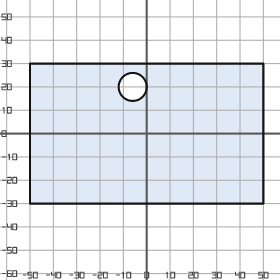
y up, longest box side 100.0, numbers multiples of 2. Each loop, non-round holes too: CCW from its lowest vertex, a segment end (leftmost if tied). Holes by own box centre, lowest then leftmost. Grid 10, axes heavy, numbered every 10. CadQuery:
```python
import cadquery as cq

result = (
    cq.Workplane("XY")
    .moveTo(-50.0, -30.0)
    .lineTo(50.0, -30.0)
    .lineTo(50.0, 30.0)
    .lineTo(-50.0, 30.0)
    .close()
    .moveTo(-6.0, 20.0)
    .circle(6.0)
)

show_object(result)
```